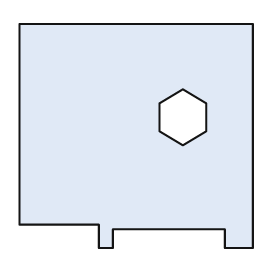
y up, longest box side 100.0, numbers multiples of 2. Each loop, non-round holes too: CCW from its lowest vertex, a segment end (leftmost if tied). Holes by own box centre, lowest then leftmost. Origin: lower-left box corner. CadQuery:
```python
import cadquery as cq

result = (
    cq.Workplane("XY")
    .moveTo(34.0, 0.0)
    .lineTo(40.0, 0.0)
    .lineTo(40.0, 8.0)
    .lineTo(88.0, 8.0)
    .lineTo(88.0, 0.0)
    .lineTo(100.0, 0.0)
    .lineTo(100.0, 96.0)
    .lineTo(0.0, 96.0)
    .lineTo(0.0, 10.0)
    .lineTo(34.0, 10.0)
    .close()
    .moveTo(70.0, 44.0)
    .lineTo(80.0, 50.0)
    .lineTo(80.0, 62.0)
    .lineTo(70.0, 68.0)
    .lineTo(60.0, 62.0)
    .lineTo(60.0, 50.0)
    .close()
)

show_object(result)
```